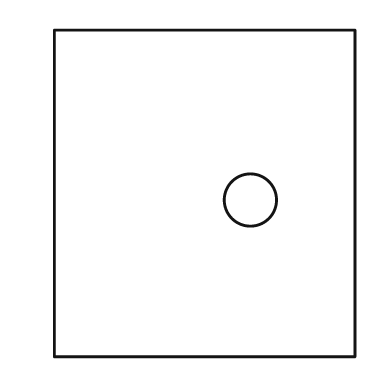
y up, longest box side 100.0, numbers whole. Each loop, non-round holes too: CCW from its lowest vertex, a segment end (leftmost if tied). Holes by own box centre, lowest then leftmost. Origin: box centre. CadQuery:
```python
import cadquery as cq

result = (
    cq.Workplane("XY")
    .moveTo(-46.0, -50.0)
    .lineTo(46.0, -50.0)
    .lineTo(46.0, 50.0)
    .lineTo(-46.0, 50.0)
    .close()
    .moveTo(14.0, -2.0)
    .circle(8.0)
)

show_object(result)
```